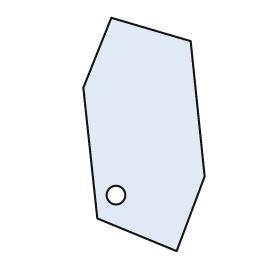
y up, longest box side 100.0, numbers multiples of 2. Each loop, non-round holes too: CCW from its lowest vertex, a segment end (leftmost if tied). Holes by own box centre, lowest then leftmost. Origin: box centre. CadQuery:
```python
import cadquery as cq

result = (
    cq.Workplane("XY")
    .moveTo(14.0, -50.0)
    .lineTo(26.0, -18.0)
    .lineTo(20.0, 40.0)
    .lineTo(-14.0, 50.0)
    .lineTo(-26.0, 20.0)
    .lineTo(-20.0, -36.0)
    .close()
    .moveTo(-12.0, -26.0)
    .circle(4.0)
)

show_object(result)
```